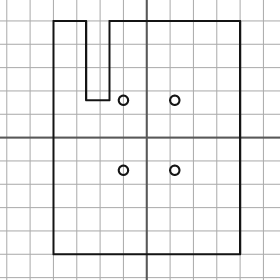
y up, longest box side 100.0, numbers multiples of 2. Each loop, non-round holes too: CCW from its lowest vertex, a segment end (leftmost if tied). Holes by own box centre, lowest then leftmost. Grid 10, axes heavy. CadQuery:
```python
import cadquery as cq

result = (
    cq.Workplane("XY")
    .moveTo(-40.0, -50.0)
    .lineTo(40.0, -50.0)
    .lineTo(40.0, 50.0)
    .lineTo(-16.0, 50.0)
    .lineTo(-16.0, 16.0)
    .lineTo(-26.0, 16.0)
    .lineTo(-26.0, 50.0)
    .lineTo(-40.0, 50.0)
    .close()
    .moveTo(-10.0, -14.0)
    .circle(2.0)
    .moveTo(12.0, -14.0)
    .circle(2.0)
    .moveTo(-10.0, 16.0)
    .circle(2.0)
    .moveTo(12.0, 16.0)
    .circle(2.0)
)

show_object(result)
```